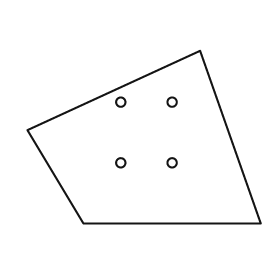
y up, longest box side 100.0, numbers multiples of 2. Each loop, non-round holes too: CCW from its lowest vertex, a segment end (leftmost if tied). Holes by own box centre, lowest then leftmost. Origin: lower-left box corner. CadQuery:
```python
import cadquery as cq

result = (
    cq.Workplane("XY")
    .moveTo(24.0, 0.0)
    .lineTo(100.0, 0.0)
    .lineTo(74.0, 74.0)
    .lineTo(0.0, 40.0)
    .close()
    .moveTo(40.0, 26.0)
    .circle(2.0)
    .moveTo(62.0, 26.0)
    .circle(2.0)
    .moveTo(40.0, 52.0)
    .circle(2.0)
    .moveTo(62.0, 52.0)
    .circle(2.0)
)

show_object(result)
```